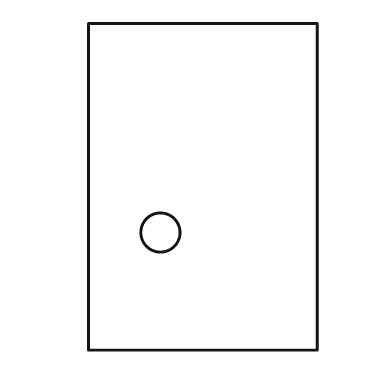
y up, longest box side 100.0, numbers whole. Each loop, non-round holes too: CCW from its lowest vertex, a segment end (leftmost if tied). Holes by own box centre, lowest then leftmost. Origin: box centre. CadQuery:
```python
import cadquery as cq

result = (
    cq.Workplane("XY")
    .moveTo(-35.0, -50.0)
    .lineTo(35.0, -50.0)
    .lineTo(35.0, 50.0)
    .lineTo(-35.0, 50.0)
    .close()
    .moveTo(-13.0, -14.0)
    .circle(6.0)
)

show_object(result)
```